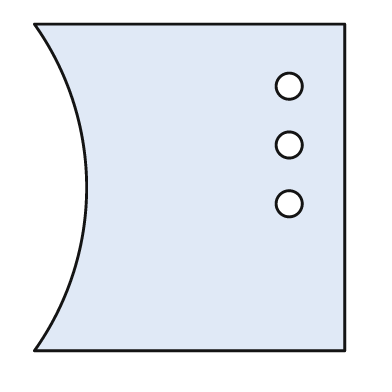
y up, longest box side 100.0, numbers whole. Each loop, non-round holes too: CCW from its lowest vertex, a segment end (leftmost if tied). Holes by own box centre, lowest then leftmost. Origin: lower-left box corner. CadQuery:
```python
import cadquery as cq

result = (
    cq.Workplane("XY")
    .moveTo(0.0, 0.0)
    .lineTo(95.0, 0.0)
    .lineTo(95.0, 100.0)
    .lineTo(0.0, 100.0)
    .threePointArc((16.0, 50.0), (0.0, 0.0))
    .close()
    .moveTo(78.0, 45.0)
    .circle(4.0)
    .moveTo(78.0, 63.0)
    .circle(4.0)
    .moveTo(78.0, 81.0)
    .circle(4.0)
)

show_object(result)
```